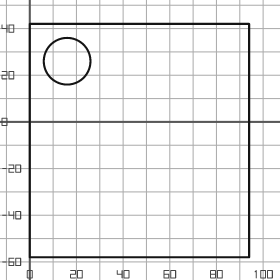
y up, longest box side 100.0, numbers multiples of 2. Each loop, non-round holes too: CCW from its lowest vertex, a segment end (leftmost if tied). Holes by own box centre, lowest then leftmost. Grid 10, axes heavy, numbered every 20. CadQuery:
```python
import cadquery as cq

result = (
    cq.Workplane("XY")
    .moveTo(0.0, -58.0)
    .lineTo(94.0, -58.0)
    .lineTo(94.0, 42.0)
    .lineTo(0.0, 42.0)
    .close()
    .moveTo(16.0, 26.0)
    .circle(10.0)
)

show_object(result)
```